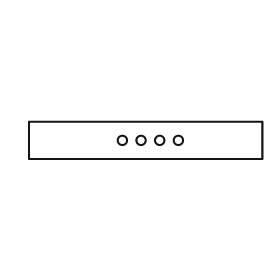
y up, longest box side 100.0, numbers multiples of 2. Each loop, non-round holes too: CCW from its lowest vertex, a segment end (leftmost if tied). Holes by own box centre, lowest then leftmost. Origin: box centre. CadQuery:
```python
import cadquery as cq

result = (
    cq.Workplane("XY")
    .moveTo(-50.0, -8.0)
    .lineTo(50.0, -8.0)
    .lineTo(50.0, 8.0)
    .lineTo(-50.0, 8.0)
    .close()
    .moveTo(-10.0, 0.0)
    .circle(2.0)
    .moveTo(-2.0, 0.0)
    .circle(2.0)
    .moveTo(6.0, 0.0)
    .circle(2.0)
    .moveTo(14.0, 0.0)
    .circle(2.0)
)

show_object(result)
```